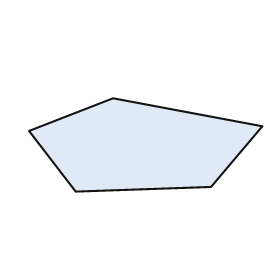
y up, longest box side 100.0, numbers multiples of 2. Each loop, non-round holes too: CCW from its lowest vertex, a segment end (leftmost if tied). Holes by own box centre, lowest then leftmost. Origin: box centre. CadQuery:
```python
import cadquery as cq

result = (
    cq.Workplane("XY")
    .moveTo(-30.0, -20.0)
    .lineTo(28.0, -18.0)
    .lineTo(50.0, 8.0)
    .lineTo(-14.0, 20.0)
    .lineTo(-50.0, 6.0)
    .close()
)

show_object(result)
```